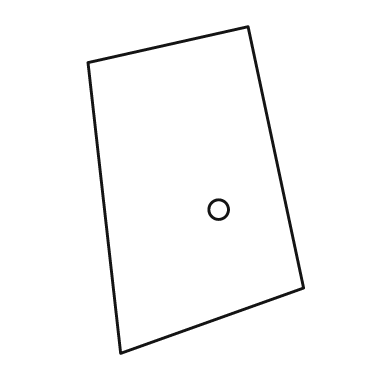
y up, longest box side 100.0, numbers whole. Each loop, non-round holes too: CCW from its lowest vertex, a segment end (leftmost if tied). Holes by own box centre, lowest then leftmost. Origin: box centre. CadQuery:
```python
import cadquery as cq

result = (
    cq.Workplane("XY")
    .moveTo(-23.0, -50.0)
    .lineTo(33.0, -30.0)
    .lineTo(16.0, 50.0)
    .lineTo(-33.0, 39.0)
    .close()
    .moveTo(7.0, -6.0)
    .circle(3.0)
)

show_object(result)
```